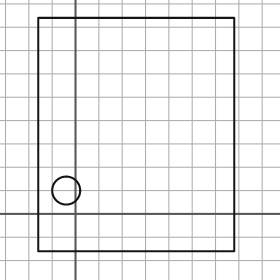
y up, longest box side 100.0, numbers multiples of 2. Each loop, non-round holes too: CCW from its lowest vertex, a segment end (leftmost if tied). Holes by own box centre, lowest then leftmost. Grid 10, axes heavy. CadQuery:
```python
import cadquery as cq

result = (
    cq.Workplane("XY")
    .moveTo(-16.0, -16.0)
    .lineTo(68.0, -16.0)
    .lineTo(68.0, 84.0)
    .lineTo(-16.0, 84.0)
    .close()
    .moveTo(-4.0, 10.0)
    .circle(6.0)
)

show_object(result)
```